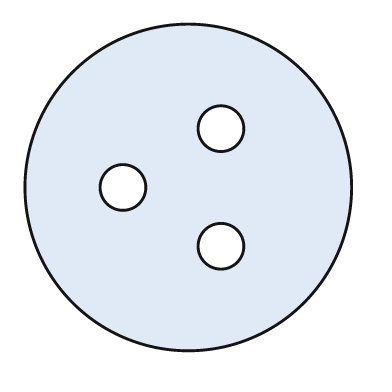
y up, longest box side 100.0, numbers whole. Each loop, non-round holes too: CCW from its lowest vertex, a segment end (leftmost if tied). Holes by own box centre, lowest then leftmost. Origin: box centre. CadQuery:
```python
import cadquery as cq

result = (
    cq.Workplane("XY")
    .moveTo(0.0, 0.0)
    .circle(50.0)
    .moveTo(10.0, -18.0)
    .circle(7.0)
    .moveTo(-20.0, 0.0)
    .circle(7.0)
    .moveTo(10.0, 18.0)
    .circle(7.0)
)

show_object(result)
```